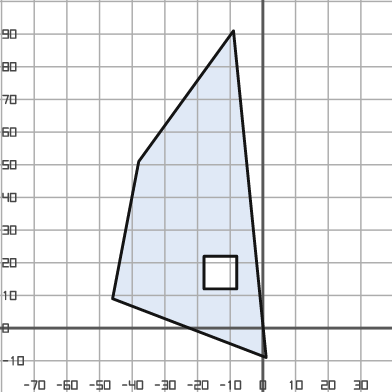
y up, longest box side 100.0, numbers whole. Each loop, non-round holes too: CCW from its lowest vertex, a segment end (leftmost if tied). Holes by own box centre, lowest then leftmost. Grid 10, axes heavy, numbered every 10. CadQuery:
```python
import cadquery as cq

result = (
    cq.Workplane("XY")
    .moveTo(1.0, -9.0)
    .lineTo(-9.0, 91.0)
    .lineTo(-38.0, 51.0)
    .lineTo(-46.0, 9.0)
    .close()
    .moveTo(-18.0, 12.0)
    .lineTo(-8.0, 12.0)
    .lineTo(-8.0, 22.0)
    .lineTo(-18.0, 22.0)
    .close()
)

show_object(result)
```